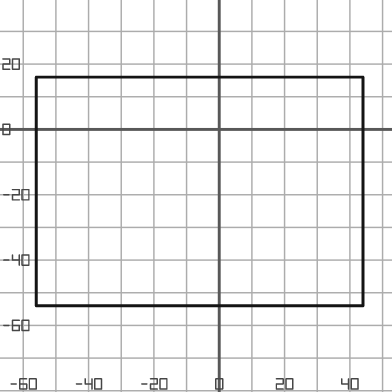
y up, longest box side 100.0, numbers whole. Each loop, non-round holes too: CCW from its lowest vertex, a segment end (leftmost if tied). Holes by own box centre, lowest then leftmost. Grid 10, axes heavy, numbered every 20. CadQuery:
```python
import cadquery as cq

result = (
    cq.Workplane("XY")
    .moveTo(-56.0, -54.0)
    .lineTo(44.0, -54.0)
    .lineTo(44.0, 16.0)
    .lineTo(-56.0, 16.0)
    .close()
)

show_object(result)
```